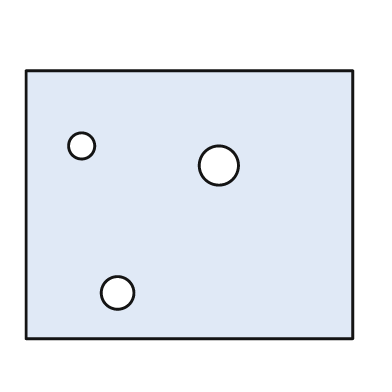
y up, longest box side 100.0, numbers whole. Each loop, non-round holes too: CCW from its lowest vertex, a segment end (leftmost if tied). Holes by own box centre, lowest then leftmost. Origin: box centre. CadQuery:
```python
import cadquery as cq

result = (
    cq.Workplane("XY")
    .moveTo(-50.0, -41.0)
    .lineTo(50.0, -41.0)
    .lineTo(50.0, 41.0)
    .lineTo(-50.0, 41.0)
    .close()
    .moveTo(-22.0, -27.0)
    .circle(5.0)
    .moveTo(9.0, 12.0)
    .circle(6.0)
    .moveTo(-33.0, 18.0)
    .circle(4.0)
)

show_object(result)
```